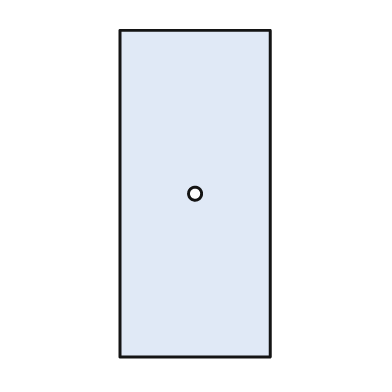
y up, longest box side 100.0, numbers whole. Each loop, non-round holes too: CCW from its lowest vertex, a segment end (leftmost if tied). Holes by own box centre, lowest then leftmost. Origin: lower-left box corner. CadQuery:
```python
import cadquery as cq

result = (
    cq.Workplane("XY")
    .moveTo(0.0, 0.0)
    .lineTo(46.0, 0.0)
    .lineTo(46.0, 100.0)
    .lineTo(0.0, 100.0)
    .close()
    .moveTo(23.0, 50.0)
    .circle(2.0)
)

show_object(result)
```